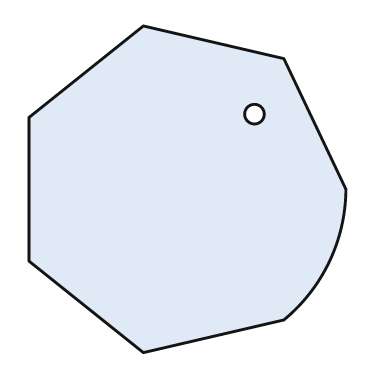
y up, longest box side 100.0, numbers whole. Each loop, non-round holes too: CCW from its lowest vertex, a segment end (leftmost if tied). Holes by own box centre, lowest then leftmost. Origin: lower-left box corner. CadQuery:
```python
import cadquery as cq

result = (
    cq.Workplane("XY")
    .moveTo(35.0, 0.0)
    .lineTo(78.0, 10.0)
    .threePointArc((92.0, 28.0), (97.0, 50.0))
    .lineTo(78.0, 90.0)
    .lineTo(35.0, 100.0)
    .lineTo(0.0, 72.0)
    .lineTo(0.0, 28.0)
    .close()
    .moveTo(69.0, 73.0)
    .circle(3.0)
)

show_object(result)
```